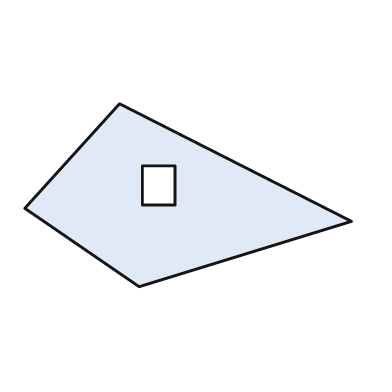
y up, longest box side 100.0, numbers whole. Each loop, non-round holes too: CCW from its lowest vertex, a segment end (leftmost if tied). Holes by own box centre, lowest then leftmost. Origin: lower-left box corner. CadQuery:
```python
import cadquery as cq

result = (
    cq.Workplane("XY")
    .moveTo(35.0, 0.0)
    .lineTo(100.0, 20.0)
    .lineTo(29.0, 56.0)
    .lineTo(0.0, 24.0)
    .close()
    .moveTo(36.0, 25.0)
    .lineTo(46.0, 25.0)
    .lineTo(46.0, 37.0)
    .lineTo(36.0, 37.0)
    .close()
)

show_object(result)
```